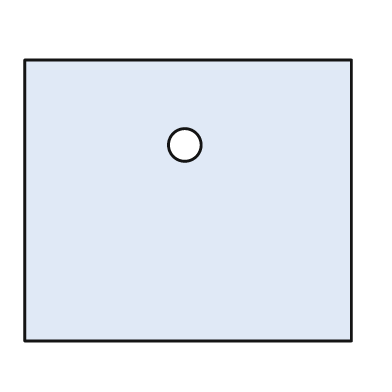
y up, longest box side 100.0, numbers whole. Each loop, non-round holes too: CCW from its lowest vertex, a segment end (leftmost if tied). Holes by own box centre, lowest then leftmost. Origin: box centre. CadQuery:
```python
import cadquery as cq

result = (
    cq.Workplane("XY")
    .moveTo(-50.0, -43.0)
    .lineTo(50.0, -43.0)
    .lineTo(50.0, 43.0)
    .lineTo(-50.0, 43.0)
    .close()
    .moveTo(-1.0, 17.0)
    .circle(5.0)
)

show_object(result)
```